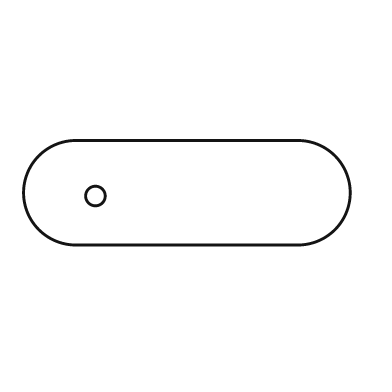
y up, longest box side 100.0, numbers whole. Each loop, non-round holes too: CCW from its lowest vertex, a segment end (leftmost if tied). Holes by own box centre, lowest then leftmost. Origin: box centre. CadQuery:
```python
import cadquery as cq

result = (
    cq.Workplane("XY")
    .moveTo(-34.0, -16.0)
    .lineTo(34.0, -16.0)
    .threePointArc((50.0, 0.0), (34.0, 16.0))
    .lineTo(-34.0, 16.0)
    .threePointArc((-50.0, 0.0), (-34.0, -16.0))
    .close()
    .moveTo(-28.0, -1.0)
    .circle(3.0)
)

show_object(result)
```